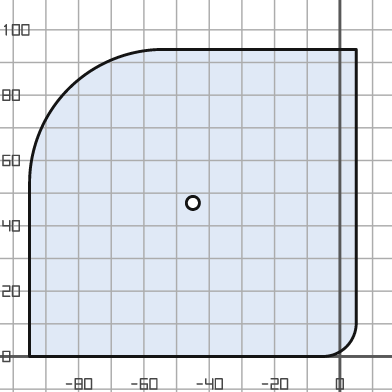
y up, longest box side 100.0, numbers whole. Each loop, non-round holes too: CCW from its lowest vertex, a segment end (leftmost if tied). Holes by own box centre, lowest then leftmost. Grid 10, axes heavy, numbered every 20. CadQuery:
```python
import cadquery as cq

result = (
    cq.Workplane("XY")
    .moveTo(-95.0, 0.0)
    .lineTo(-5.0, 0.0)
    .threePointArc((2.0, 3.0), (5.0, 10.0))
    .lineTo(5.0, 94.0)
    .lineTo(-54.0, 94.0)
    .threePointArc((-83.0, 82.0), (-95.0, 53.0))
    .close()
    .moveTo(-45.0, 47.0)
    .circle(2.0)
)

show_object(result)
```